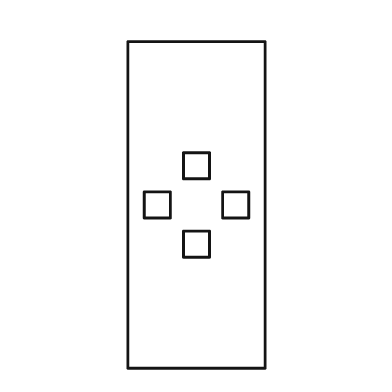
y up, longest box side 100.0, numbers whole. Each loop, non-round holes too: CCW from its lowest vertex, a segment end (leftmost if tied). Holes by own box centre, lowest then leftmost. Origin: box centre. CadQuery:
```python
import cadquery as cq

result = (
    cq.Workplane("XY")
    .moveTo(-21.0, -50.0)
    .lineTo(21.0, -50.0)
    .lineTo(21.0, 50.0)
    .lineTo(-21.0, 50.0)
    .close()
    .moveTo(-4.0, -16.0)
    .lineTo(4.0, -16.0)
    .lineTo(4.0, -8.0)
    .lineTo(-4.0, -8.0)
    .close()
    .moveTo(-16.0, -4.0)
    .lineTo(-8.0, -4.0)
    .lineTo(-8.0, 4.0)
    .lineTo(-16.0, 4.0)
    .close()
    .moveTo(8.0, -4.0)
    .lineTo(16.0, -4.0)
    .lineTo(16.0, 4.0)
    .lineTo(8.0, 4.0)
    .close()
    .moveTo(-4.0, 8.0)
    .lineTo(4.0, 8.0)
    .lineTo(4.0, 16.0)
    .lineTo(-4.0, 16.0)
    .close()
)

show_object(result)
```